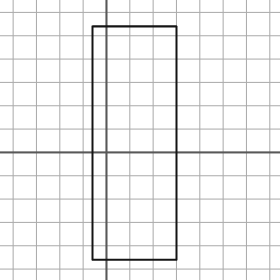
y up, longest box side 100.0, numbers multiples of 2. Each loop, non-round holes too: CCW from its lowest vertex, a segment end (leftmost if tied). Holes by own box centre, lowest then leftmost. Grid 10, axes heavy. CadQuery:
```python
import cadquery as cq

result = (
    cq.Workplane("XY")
    .moveTo(-6.0, -46.0)
    .lineTo(30.0, -46.0)
    .lineTo(30.0, 54.0)
    .lineTo(-6.0, 54.0)
    .close()
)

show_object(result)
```